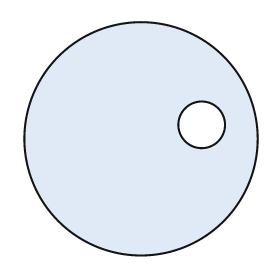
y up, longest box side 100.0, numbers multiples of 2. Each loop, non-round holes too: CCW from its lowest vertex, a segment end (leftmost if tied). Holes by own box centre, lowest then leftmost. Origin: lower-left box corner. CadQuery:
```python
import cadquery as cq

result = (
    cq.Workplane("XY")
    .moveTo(50.0, 50.0)
    .circle(50.0)
    .moveTo(76.0, 56.0)
    .circle(10.0)
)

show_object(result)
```